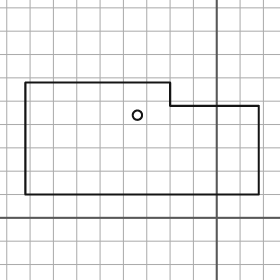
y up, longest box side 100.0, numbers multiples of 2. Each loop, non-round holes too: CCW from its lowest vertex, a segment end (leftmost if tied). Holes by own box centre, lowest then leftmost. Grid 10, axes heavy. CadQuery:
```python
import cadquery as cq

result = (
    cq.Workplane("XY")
    .moveTo(-82.0, 10.0)
    .lineTo(18.0, 10.0)
    .lineTo(18.0, 48.0)
    .lineTo(-20.0, 48.0)
    .lineTo(-20.0, 58.0)
    .lineTo(-82.0, 58.0)
    .close()
    .moveTo(-34.0, 44.0)
    .circle(2.0)
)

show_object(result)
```